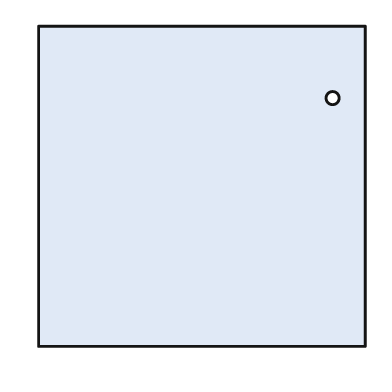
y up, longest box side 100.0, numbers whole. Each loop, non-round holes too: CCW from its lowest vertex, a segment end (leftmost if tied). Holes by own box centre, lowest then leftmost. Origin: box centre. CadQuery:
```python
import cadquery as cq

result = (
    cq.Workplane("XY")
    .moveTo(-50.0, -49.0)
    .lineTo(50.0, -49.0)
    .lineTo(50.0, 49.0)
    .lineTo(-50.0, 49.0)
    .close()
    .moveTo(40.0, 27.0)
    .circle(2.0)
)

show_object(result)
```